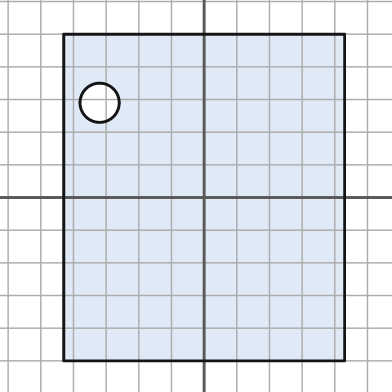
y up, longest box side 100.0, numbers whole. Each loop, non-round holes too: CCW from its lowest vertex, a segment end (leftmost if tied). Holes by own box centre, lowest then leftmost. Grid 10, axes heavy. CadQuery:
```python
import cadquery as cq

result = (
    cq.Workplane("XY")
    .moveTo(-43.0, -50.0)
    .lineTo(43.0, -50.0)
    .lineTo(43.0, 50.0)
    .lineTo(-43.0, 50.0)
    .close()
    .moveTo(-32.0, 29.0)
    .circle(6.0)
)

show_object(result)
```